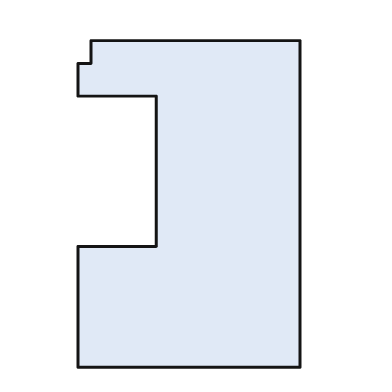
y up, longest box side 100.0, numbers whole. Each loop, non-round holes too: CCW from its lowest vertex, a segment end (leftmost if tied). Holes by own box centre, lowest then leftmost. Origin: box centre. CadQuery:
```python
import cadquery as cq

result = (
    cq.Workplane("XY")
    .moveTo(-34.0, -50.0)
    .lineTo(34.0, -50.0)
    .lineTo(34.0, 50.0)
    .lineTo(-30.0, 50.0)
    .lineTo(-30.0, 43.0)
    .lineTo(-34.0, 43.0)
    .lineTo(-34.0, 33.0)
    .lineTo(-10.0, 33.0)
    .lineTo(-10.0, -13.0)
    .lineTo(-34.0, -13.0)
    .close()
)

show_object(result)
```